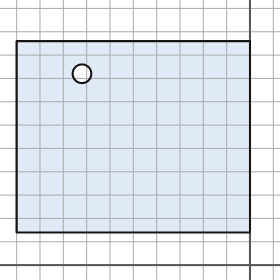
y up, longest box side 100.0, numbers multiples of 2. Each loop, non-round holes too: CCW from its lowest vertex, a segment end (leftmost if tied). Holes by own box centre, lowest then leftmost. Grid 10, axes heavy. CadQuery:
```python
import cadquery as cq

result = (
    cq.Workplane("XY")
    .moveTo(-100.0, 14.0)
    .lineTo(0.0, 14.0)
    .lineTo(0.0, 96.0)
    .lineTo(-100.0, 96.0)
    .close()
    .moveTo(-72.0, 82.0)
    .circle(4.0)
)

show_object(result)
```